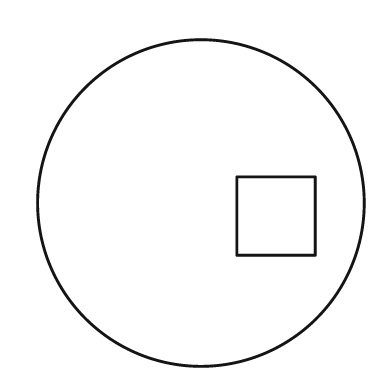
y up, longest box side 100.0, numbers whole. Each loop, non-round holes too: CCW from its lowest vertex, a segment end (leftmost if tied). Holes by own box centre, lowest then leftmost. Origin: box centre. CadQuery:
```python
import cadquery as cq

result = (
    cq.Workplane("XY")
    .moveTo(0.0, 0.0)
    .circle(50.0)
    .moveTo(11.0, -16.0)
    .lineTo(35.0, -16.0)
    .lineTo(35.0, 8.0)
    .lineTo(11.0, 8.0)
    .close()
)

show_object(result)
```